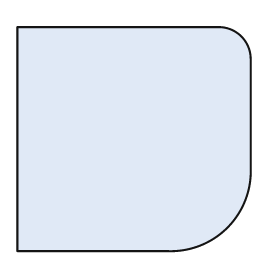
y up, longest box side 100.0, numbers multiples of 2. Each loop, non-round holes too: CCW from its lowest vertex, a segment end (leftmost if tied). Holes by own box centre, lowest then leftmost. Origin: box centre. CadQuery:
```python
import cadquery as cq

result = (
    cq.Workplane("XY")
    .moveTo(-50.0, -48.0)
    .lineTo(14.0, -48.0)
    .threePointArc((40.0, -38.0), (50.0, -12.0))
    .lineTo(50.0, 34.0)
    .threePointArc((46.0, 44.0), (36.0, 48.0))
    .lineTo(-50.0, 48.0)
    .close()
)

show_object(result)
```